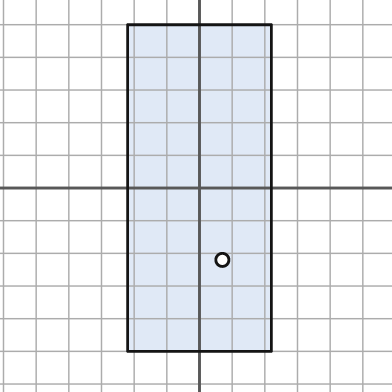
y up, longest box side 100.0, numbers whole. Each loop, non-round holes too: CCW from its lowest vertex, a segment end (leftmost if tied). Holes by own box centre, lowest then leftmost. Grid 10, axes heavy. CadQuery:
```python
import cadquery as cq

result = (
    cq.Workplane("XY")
    .moveTo(-22.0, -50.0)
    .lineTo(22.0, -50.0)
    .lineTo(22.0, 50.0)
    .lineTo(-22.0, 50.0)
    .close()
    .moveTo(7.0, -22.0)
    .circle(2.0)
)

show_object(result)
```